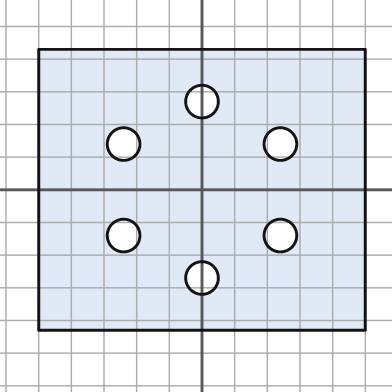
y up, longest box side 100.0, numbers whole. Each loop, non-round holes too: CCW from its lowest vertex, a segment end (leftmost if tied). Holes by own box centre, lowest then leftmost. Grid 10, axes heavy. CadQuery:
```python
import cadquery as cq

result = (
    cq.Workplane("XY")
    .moveTo(-50.0, -43.0)
    .lineTo(50.0, -43.0)
    .lineTo(50.0, 43.0)
    .lineTo(-50.0, 43.0)
    .close()
    .moveTo(0.0, -27.0)
    .circle(5.0)
    .moveTo(-24.0, -14.0)
    .circle(5.0)
    .moveTo(24.0, -14.0)
    .circle(5.0)
    .moveTo(-24.0, 14.0)
    .circle(5.0)
    .moveTo(24.0, 14.0)
    .circle(5.0)
    .moveTo(0.0, 27.0)
    .circle(5.0)
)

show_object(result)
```